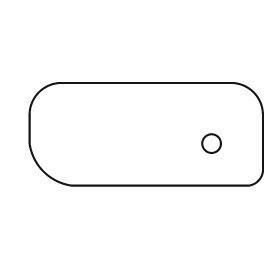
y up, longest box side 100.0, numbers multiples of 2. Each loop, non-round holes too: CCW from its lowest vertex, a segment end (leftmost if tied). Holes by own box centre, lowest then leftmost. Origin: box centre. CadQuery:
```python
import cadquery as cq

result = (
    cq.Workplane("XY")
    .moveTo(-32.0, -22.0)
    .lineTo(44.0, -22.0)
    .threePointArc((48.0, -20.0), (50.0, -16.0))
    .lineTo(50.0, 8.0)
    .threePointArc((46.0, 18.0), (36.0, 22.0))
    .lineTo(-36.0, 22.0)
    .threePointArc((-46.0, 18.0), (-50.0, 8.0))
    .lineTo(-50.0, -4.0)
    .threePointArc((-44.0, -16.0), (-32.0, -22.0))
    .close()
    .moveTo(28.0, -4.0)
    .circle(4.0)
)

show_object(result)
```